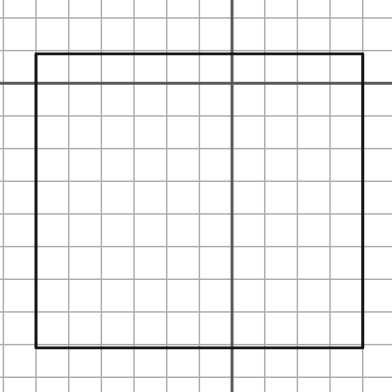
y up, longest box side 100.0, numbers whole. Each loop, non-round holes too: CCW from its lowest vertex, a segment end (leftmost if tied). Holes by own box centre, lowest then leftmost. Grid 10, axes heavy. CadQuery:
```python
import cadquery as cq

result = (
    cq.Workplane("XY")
    .moveTo(-60.0, -81.0)
    .lineTo(40.0, -81.0)
    .lineTo(40.0, 9.0)
    .lineTo(-60.0, 9.0)
    .close()
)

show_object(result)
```